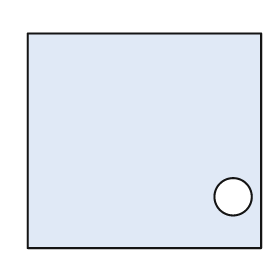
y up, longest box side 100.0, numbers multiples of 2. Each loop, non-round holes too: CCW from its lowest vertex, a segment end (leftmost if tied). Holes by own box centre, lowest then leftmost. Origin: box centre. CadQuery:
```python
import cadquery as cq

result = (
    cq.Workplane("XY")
    .moveTo(-50.0, -46.0)
    .lineTo(50.0, -46.0)
    .lineTo(50.0, 46.0)
    .lineTo(-50.0, 46.0)
    .close()
    .moveTo(38.0, -24.0)
    .circle(8.0)
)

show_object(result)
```